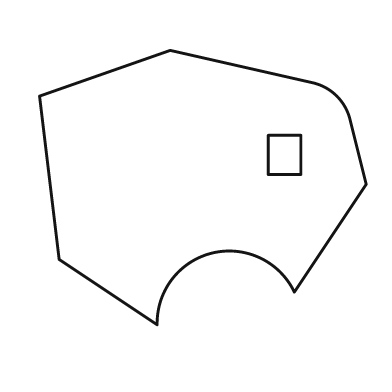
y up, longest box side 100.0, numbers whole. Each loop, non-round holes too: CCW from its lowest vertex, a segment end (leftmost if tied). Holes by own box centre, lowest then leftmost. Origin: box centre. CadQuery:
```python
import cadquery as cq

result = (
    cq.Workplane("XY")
    .moveTo(-14.0, -42.0)
    .threePointArc((3.0, -20.0), (28.0, -32.0))
    .lineTo(50.0, 1.0)
    .lineTo(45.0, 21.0)
    .threePointArc((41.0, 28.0), (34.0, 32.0))
    .lineTo(-10.0, 42.0)
    .lineTo(-50.0, 28.0)
    .lineTo(-44.0, -22.0)
    .close()
    .moveTo(20.0, 4.0)
    .lineTo(30.0, 4.0)
    .lineTo(30.0, 16.0)
    .lineTo(20.0, 16.0)
    .close()
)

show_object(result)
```